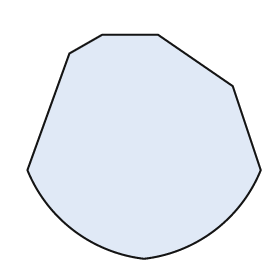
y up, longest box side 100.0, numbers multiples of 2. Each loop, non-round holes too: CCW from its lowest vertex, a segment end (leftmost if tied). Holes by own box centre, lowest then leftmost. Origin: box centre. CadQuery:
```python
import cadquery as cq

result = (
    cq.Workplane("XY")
    .moveTo(0.0, -48.0)
    .threePointArc((30.0, -36.0), (50.0, -10.0))
    .lineTo(38.0, 26.0)
    .lineTo(6.0, 48.0)
    .lineTo(-18.0, 48.0)
    .lineTo(-32.0, 40.0)
    .lineTo(-50.0, -10.0)
    .threePointArc((-30.0, -36.0), (0.0, -48.0))
    .close()
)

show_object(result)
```